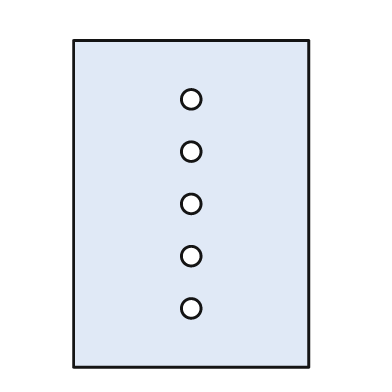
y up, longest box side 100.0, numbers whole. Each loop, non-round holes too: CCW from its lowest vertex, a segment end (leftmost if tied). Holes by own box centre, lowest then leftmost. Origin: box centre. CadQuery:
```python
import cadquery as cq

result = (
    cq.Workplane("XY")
    .moveTo(-36.0, -50.0)
    .lineTo(36.0, -50.0)
    .lineTo(36.0, 50.0)
    .lineTo(-36.0, 50.0)
    .close()
    .moveTo(0.0, -32.0)
    .circle(3.0)
    .moveTo(0.0, -16.0)
    .circle(3.0)
    .moveTo(0.0, 0.0)
    .circle(3.0)
    .moveTo(0.0, 16.0)
    .circle(3.0)
    .moveTo(0.0, 32.0)
    .circle(3.0)
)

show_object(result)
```